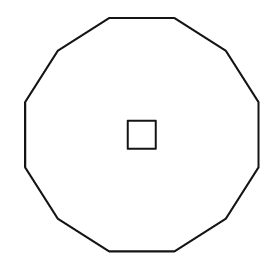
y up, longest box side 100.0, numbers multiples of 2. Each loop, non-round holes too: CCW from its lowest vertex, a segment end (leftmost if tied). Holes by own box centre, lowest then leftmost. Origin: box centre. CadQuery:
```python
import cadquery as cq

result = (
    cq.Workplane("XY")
    .moveTo(-14.0, -50.0)
    .lineTo(14.0, -50.0)
    .lineTo(36.0, -36.0)
    .lineTo(50.0, -14.0)
    .lineTo(50.0, 14.0)
    .lineTo(36.0, 36.0)
    .lineTo(14.0, 50.0)
    .lineTo(-14.0, 50.0)
    .lineTo(-36.0, 36.0)
    .lineTo(-50.0, 14.0)
    .lineTo(-50.0, -14.0)
    .lineTo(-36.0, -36.0)
    .close()
    .moveTo(-6.0, -6.0)
    .lineTo(6.0, -6.0)
    .lineTo(6.0, 6.0)
    .lineTo(-6.0, 6.0)
    .close()
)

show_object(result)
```